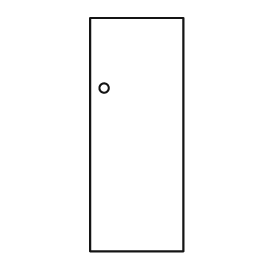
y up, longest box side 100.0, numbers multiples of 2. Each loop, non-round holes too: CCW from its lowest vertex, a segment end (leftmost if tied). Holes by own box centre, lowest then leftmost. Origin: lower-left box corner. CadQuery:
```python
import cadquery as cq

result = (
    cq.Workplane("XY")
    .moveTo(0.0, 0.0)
    .lineTo(40.0, 0.0)
    .lineTo(40.0, 100.0)
    .lineTo(0.0, 100.0)
    .close()
    .moveTo(6.0, 70.0)
    .circle(2.0)
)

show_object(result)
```